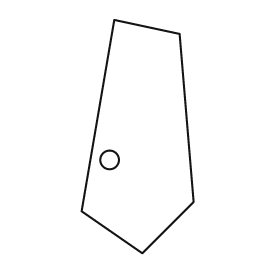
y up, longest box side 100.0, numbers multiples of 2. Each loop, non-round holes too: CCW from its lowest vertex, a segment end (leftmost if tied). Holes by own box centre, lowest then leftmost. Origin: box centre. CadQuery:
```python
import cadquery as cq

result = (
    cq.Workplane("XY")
    .moveTo(2.0, -50.0)
    .lineTo(24.0, -28.0)
    .lineTo(18.0, 44.0)
    .lineTo(-10.0, 50.0)
    .lineTo(-24.0, -32.0)
    .close()
    .moveTo(-12.0, -10.0)
    .circle(4.0)
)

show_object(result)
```